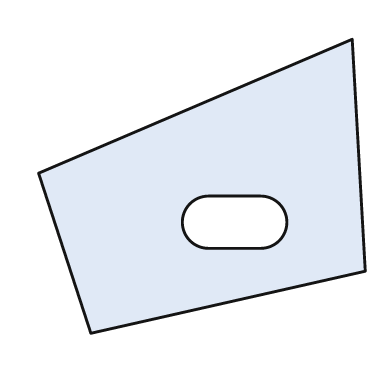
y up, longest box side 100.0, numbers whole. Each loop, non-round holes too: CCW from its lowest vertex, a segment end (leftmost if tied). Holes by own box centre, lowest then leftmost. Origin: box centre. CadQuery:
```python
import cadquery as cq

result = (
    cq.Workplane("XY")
    .moveTo(-34.0, -45.0)
    .lineTo(50.0, -26.0)
    .lineTo(46.0, 45.0)
    .lineTo(-50.0, 4.0)
    .close()
    .moveTo(2.0, -19.0)
    .lineTo(18.0, -19.0)
    .threePointArc((26.0, -11.0), (18.0, -3.0))
    .lineTo(2.0, -3.0)
    .threePointArc((-6.0, -11.0), (2.0, -19.0))
    .close()
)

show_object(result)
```